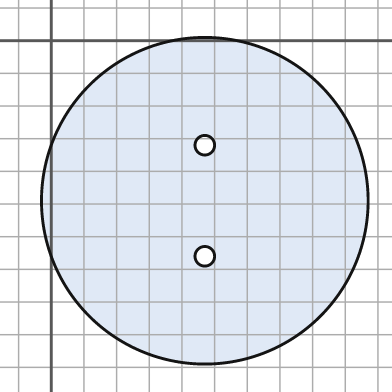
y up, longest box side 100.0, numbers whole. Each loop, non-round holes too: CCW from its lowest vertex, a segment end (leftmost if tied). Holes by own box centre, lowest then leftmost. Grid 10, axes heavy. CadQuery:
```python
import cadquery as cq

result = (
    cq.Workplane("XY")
    .moveTo(47.0, -49.0)
    .circle(50.0)
    .moveTo(47.0, -66.0)
    .circle(3.0)
    .moveTo(47.0, -32.0)
    .circle(3.0)
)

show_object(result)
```